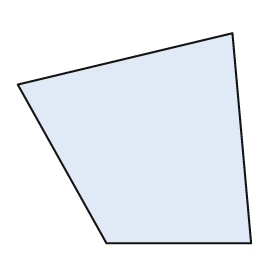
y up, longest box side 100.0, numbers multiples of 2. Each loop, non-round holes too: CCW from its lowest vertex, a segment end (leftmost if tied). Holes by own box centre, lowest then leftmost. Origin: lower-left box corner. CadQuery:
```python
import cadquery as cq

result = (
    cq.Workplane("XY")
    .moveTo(38.0, 0.0)
    .lineTo(100.0, 0.0)
    .lineTo(92.0, 90.0)
    .lineTo(0.0, 68.0)
    .close()
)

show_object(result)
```